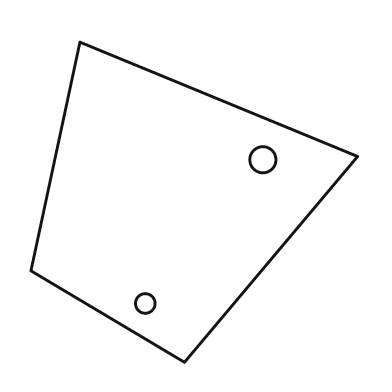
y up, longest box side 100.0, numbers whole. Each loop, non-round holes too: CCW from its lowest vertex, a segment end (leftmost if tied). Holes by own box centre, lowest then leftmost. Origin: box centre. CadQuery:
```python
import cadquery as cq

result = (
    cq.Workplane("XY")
    .moveTo(-3.0, -49.0)
    .lineTo(50.0, 14.0)
    .lineTo(-35.0, 49.0)
    .lineTo(-50.0, -21.0)
    .close()
    .moveTo(-15.0, -31.0)
    .circle(3.0)
    .moveTo(21.0, 13.0)
    .circle(4.0)
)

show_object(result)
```